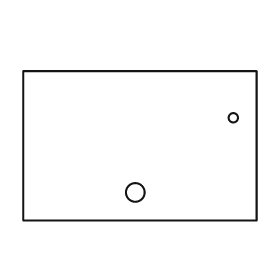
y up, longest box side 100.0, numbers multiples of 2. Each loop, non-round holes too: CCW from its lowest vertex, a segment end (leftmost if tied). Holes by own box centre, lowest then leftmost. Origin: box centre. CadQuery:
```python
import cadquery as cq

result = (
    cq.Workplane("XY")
    .moveTo(-50.0, -32.0)
    .lineTo(50.0, -32.0)
    .lineTo(50.0, 32.0)
    .lineTo(-50.0, 32.0)
    .close()
    .moveTo(-2.0, -20.0)
    .circle(4.0)
    .moveTo(40.0, 12.0)
    .circle(2.0)
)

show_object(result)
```